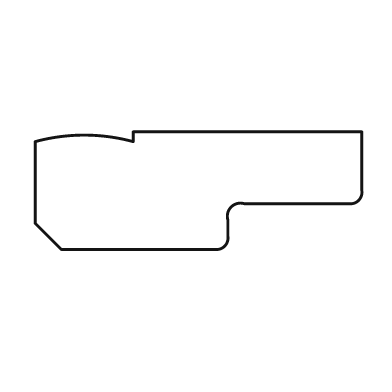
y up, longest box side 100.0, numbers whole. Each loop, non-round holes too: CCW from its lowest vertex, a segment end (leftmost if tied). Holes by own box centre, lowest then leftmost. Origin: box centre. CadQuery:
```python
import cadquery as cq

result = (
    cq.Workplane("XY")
    .moveTo(-42.0, -18.0)
    .lineTo(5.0, -18.0)
    .threePointArc((8.0, -17.0), (9.0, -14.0))
    .lineTo(9.0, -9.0)
    .threePointArc((10.0, -5.0), (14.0, -4.0))
    .lineTo(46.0, -4.0)
    .threePointArc((49.0, -3.0), (50.0, 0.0))
    .lineTo(50.0, 18.0)
    .lineTo(-20.0, 18.0)
    .lineTo(-20.0, 15.0)
    .threePointArc((-35.0, 17.0), (-50.0, 15.0))
    .lineTo(-50.0, -10.0)
    .close()
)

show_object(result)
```